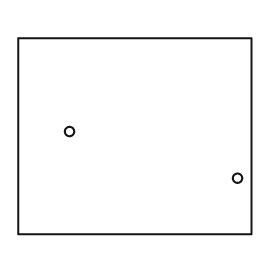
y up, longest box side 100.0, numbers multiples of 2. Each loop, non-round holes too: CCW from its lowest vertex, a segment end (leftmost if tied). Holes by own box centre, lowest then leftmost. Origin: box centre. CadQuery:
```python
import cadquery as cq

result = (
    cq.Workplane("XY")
    .moveTo(-50.0, -42.0)
    .lineTo(50.0, -42.0)
    .lineTo(50.0, 42.0)
    .lineTo(-50.0, 42.0)
    .close()
    .moveTo(44.0, -18.0)
    .circle(2.0)
    .moveTo(-28.0, 2.0)
    .circle(2.0)
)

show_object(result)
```